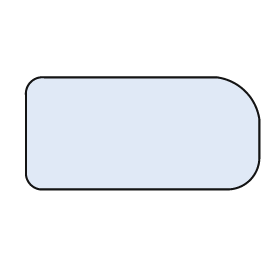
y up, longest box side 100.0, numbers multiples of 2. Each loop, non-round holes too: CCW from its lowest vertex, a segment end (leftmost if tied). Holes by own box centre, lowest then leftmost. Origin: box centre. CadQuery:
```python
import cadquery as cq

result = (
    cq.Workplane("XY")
    .moveTo(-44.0, -24.0)
    .lineTo(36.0, -24.0)
    .threePointArc((46.0, -20.0), (50.0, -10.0))
    .lineTo(50.0, 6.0)
    .threePointArc((44.0, 18.0), (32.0, 24.0))
    .lineTo(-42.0, 24.0)
    .threePointArc((-48.0, 22.0), (-50.0, 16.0))
    .lineTo(-50.0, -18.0)
    .threePointArc((-48.0, -22.0), (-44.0, -24.0))
    .close()
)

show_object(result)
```